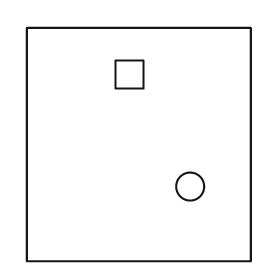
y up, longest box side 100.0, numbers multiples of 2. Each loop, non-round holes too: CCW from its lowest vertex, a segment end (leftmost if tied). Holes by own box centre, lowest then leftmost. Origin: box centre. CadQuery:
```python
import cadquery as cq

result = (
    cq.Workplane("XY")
    .moveTo(-48.0, -50.0)
    .lineTo(48.0, -50.0)
    .lineTo(48.0, 50.0)
    .lineTo(-48.0, 50.0)
    .close()
    .moveTo(22.0, -18.0)
    .circle(6.0)
    .moveTo(-10.0, 24.0)
    .lineTo(2.0, 24.0)
    .lineTo(2.0, 36.0)
    .lineTo(-10.0, 36.0)
    .close()
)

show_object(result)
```